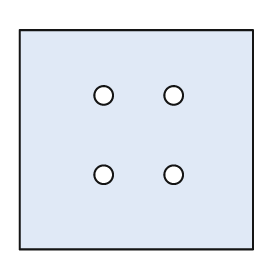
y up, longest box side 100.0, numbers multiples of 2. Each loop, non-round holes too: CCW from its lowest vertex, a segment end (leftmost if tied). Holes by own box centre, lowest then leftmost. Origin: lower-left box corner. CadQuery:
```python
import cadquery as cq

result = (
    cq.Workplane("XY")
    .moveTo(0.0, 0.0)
    .lineTo(100.0, 0.0)
    .lineTo(100.0, 94.0)
    .lineTo(0.0, 94.0)
    .close()
    .moveTo(36.0, 32.0)
    .circle(4.0)
    .moveTo(66.0, 32.0)
    .circle(4.0)
    .moveTo(36.0, 66.0)
    .circle(4.0)
    .moveTo(66.0, 66.0)
    .circle(4.0)
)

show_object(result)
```